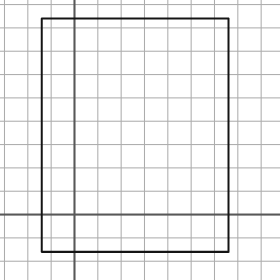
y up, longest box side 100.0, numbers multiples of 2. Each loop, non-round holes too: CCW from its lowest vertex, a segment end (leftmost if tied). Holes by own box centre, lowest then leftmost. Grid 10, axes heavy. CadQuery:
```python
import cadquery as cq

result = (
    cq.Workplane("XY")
    .moveTo(-14.0, -16.0)
    .lineTo(66.0, -16.0)
    .lineTo(66.0, 84.0)
    .lineTo(-14.0, 84.0)
    .close()
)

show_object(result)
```